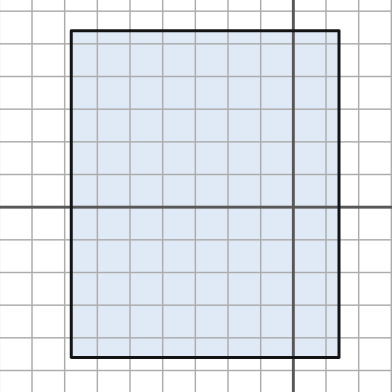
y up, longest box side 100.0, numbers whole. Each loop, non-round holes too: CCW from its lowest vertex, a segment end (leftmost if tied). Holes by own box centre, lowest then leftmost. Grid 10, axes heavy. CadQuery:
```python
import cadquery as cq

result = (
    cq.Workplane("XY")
    .moveTo(-68.0, -46.0)
    .lineTo(14.0, -46.0)
    .lineTo(14.0, 54.0)
    .lineTo(-68.0, 54.0)
    .close()
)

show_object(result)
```